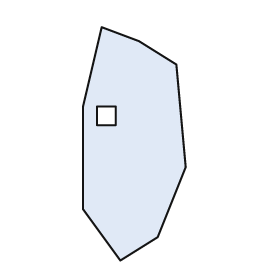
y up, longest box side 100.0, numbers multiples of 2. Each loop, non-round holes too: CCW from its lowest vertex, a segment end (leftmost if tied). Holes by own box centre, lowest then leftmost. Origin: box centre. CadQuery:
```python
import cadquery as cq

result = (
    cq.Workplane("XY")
    .moveTo(-6.0, -50.0)
    .lineTo(10.0, -40.0)
    .lineTo(22.0, -10.0)
    .lineTo(18.0, 34.0)
    .lineTo(2.0, 44.0)
    .lineTo(-14.0, 50.0)
    .lineTo(-22.0, 16.0)
    .lineTo(-22.0, -28.0)
    .close()
    .moveTo(-16.0, 8.0)
    .lineTo(-8.0, 8.0)
    .lineTo(-8.0, 16.0)
    .lineTo(-16.0, 16.0)
    .close()
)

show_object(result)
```